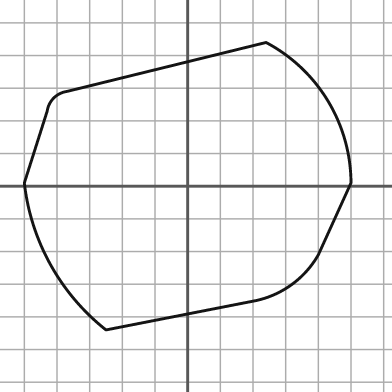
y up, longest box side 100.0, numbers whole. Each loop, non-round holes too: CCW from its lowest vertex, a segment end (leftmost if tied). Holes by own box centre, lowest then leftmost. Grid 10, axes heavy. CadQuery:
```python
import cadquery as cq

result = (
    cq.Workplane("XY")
    .moveTo(-25.0, -44.0)
    .lineTo(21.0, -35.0)
    .threePointArc((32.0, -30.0), (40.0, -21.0))
    .lineTo(50.0, 1.0)
    .threePointArc((43.0, 26.0), (24.0, 44.0))
    .lineTo(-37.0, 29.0)
    .threePointArc((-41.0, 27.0), (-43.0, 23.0))
    .lineTo(-50.0, 1.0)
    .threePointArc((-42.0, -24.0), (-25.0, -44.0))
    .close()
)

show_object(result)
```